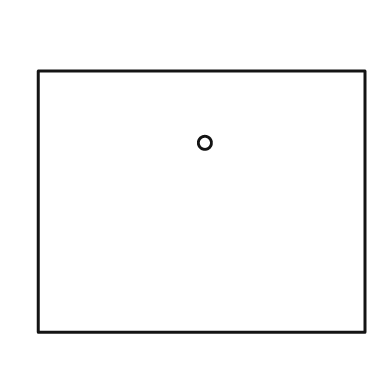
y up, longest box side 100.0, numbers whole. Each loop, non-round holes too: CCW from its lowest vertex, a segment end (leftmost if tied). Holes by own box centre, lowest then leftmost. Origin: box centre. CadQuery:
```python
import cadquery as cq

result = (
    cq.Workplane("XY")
    .moveTo(-50.0, -40.0)
    .lineTo(50.0, -40.0)
    .lineTo(50.0, 40.0)
    .lineTo(-50.0, 40.0)
    .close()
    .moveTo(1.0, 18.0)
    .circle(2.0)
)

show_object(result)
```